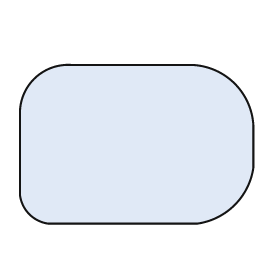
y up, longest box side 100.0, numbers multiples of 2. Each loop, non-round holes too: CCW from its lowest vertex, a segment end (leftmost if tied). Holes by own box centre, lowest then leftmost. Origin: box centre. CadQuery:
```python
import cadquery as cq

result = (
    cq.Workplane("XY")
    .moveTo(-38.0, -34.0)
    .lineTo(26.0, -34.0)
    .threePointArc((42.0, -26.0), (50.0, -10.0))
    .lineTo(50.0, 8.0)
    .threePointArc((42.0, 26.0), (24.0, 34.0))
    .lineTo(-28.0, 34.0)
    .threePointArc((-44.0, 28.0), (-50.0, 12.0))
    .lineTo(-50.0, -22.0)
    .threePointArc((-46.0, -30.0), (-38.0, -34.0))
    .close()
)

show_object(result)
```